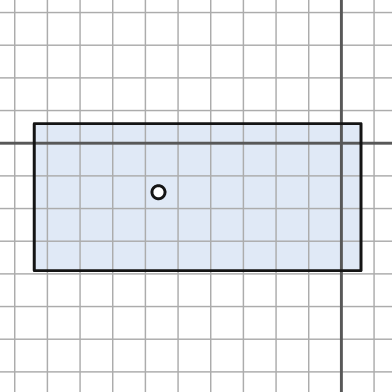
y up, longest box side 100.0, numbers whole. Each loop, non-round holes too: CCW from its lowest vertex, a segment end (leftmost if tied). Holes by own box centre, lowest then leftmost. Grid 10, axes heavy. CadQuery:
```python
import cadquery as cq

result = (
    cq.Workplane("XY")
    .moveTo(-94.0, -39.0)
    .lineTo(6.0, -39.0)
    .lineTo(6.0, 6.0)
    .lineTo(-94.0, 6.0)
    .close()
    .moveTo(-56.0, -15.0)
    .circle(2.0)
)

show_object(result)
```